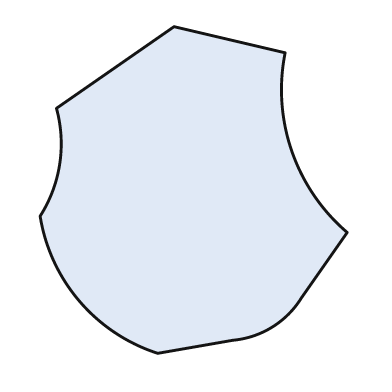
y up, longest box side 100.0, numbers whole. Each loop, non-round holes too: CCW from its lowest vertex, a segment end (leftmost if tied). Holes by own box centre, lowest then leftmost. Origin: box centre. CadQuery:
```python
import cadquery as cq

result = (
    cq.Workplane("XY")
    .moveTo(-11.0, -50.0)
    .lineTo(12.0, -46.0)
    .threePointArc((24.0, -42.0), (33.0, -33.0))
    .lineTo(47.0, -13.0)
    .threePointArc((30.0, 12.0), (28.0, 42.0))
    .lineTo(-6.0, 50.0)
    .lineTo(-42.0, 25.0)
    .threePointArc((-41.0, 8.0), (-47.0, -8.0))
    .threePointArc((-35.0, -34.0), (-11.0, -50.0))
    .close()
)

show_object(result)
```